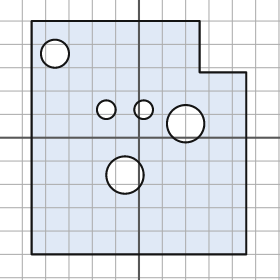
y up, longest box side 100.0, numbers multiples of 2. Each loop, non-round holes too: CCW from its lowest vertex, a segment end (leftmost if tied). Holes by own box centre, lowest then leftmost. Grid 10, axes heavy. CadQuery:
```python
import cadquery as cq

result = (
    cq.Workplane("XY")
    .moveTo(-46.0, -50.0)
    .lineTo(46.0, -50.0)
    .lineTo(46.0, 28.0)
    .lineTo(26.0, 28.0)
    .lineTo(26.0, 50.0)
    .lineTo(-46.0, 50.0)
    .close()
    .moveTo(-6.0, -16.0)
    .circle(8.0)
    .moveTo(20.0, 6.0)
    .circle(8.0)
    .moveTo(-14.0, 12.0)
    .circle(4.0)
    .moveTo(2.0, 12.0)
    .circle(4.0)
    .moveTo(-36.0, 36.0)
    .circle(6.0)
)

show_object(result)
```